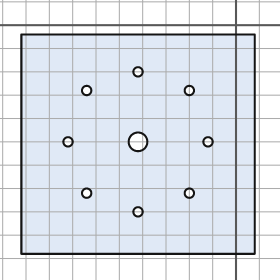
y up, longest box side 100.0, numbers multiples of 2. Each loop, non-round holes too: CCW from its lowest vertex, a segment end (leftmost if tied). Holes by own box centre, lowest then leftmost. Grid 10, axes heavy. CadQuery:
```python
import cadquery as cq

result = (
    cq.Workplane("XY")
    .moveTo(-92.0, -98.0)
    .lineTo(8.0, -98.0)
    .lineTo(8.0, -4.0)
    .lineTo(-92.0, -4.0)
    .close()
    .moveTo(-42.0, -80.0)
    .circle(2.0)
    .moveTo(-64.0, -72.0)
    .circle(2.0)
    .moveTo(-20.0, -72.0)
    .circle(2.0)
    .moveTo(-72.0, -50.0)
    .circle(2.0)
    .moveTo(-42.0, -50.0)
    .circle(4.0)
    .moveTo(-12.0, -50.0)
    .circle(2.0)
    .moveTo(-64.0, -28.0)
    .circle(2.0)
    .moveTo(-20.0, -28.0)
    .circle(2.0)
    .moveTo(-42.0, -20.0)
    .circle(2.0)
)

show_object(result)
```